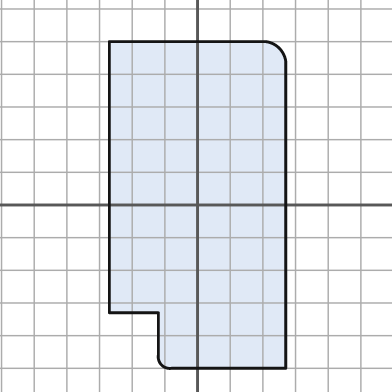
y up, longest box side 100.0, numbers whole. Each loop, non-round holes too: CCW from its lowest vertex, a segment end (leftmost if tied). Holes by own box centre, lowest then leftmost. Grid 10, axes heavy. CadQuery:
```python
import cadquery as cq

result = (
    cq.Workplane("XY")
    .moveTo(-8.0, -50.0)
    .lineTo(27.0, -50.0)
    .lineTo(27.0, 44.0)
    .threePointArc((25.0, 48.0), (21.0, 50.0))
    .lineTo(-27.0, 50.0)
    .lineTo(-27.0, -33.0)
    .lineTo(-12.0, -33.0)
    .lineTo(-12.0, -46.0)
    .threePointArc((-11.0, -49.0), (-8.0, -50.0))
    .close()
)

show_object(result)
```